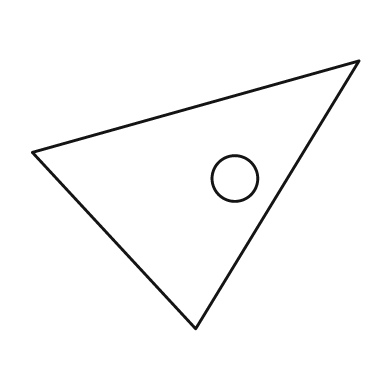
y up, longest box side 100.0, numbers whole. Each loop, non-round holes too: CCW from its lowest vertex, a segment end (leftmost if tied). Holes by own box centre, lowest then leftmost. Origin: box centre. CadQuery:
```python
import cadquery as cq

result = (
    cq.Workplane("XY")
    .moveTo(0.0, -41.0)
    .lineTo(50.0, 41.0)
    .lineTo(-50.0, 13.0)
    .close()
    .moveTo(12.0, 5.0)
    .circle(7.0)
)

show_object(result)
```